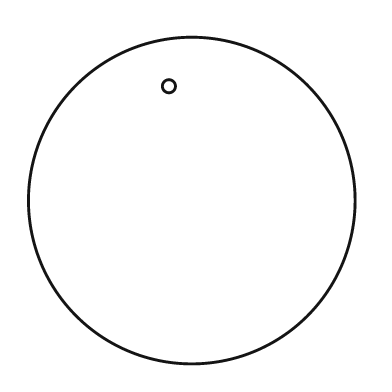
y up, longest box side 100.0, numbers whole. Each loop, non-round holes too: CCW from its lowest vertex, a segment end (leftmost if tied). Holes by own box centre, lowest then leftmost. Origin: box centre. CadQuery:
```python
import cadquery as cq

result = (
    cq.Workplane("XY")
    .moveTo(0.0, 0.0)
    .circle(50.0)
    .moveTo(-7.0, 35.0)
    .circle(2.0)
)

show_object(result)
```